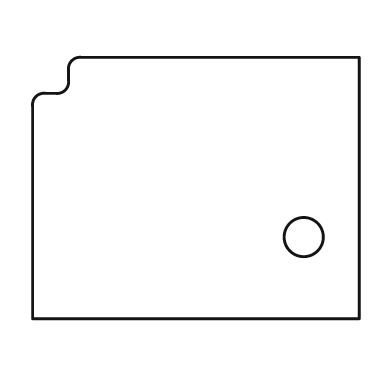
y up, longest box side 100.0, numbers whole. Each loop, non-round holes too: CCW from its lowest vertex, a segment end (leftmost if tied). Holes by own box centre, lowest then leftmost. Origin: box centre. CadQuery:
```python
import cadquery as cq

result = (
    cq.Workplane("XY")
    .moveTo(-50.0, -40.0)
    .lineTo(50.0, -40.0)
    .lineTo(50.0, 40.0)
    .lineTo(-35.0, 40.0)
    .threePointArc((-38.0, 39.0), (-39.0, 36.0))
    .lineTo(-39.0, 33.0)
    .threePointArc((-40.0, 30.0), (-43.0, 29.0))
    .lineTo(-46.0, 29.0)
    .threePointArc((-49.0, 28.0), (-50.0, 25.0))
    .close()
    .moveTo(33.0, -15.0)
    .circle(6.0)
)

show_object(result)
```